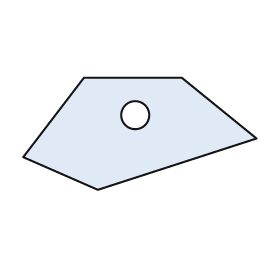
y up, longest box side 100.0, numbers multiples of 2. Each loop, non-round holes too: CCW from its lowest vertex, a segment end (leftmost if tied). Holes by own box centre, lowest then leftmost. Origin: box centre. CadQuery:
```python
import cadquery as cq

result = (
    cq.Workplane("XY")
    .moveTo(-18.0, -24.0)
    .lineTo(50.0, -2.0)
    .lineTo(18.0, 24.0)
    .lineTo(-24.0, 24.0)
    .lineTo(-50.0, -10.0)
    .close()
    .moveTo(-2.0, 8.0)
    .circle(6.0)
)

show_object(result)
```